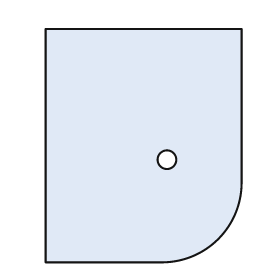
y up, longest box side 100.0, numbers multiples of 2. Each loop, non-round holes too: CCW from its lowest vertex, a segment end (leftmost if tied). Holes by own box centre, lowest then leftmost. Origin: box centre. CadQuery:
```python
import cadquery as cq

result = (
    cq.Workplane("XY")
    .moveTo(-42.0, -50.0)
    .lineTo(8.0, -50.0)
    .threePointArc((32.0, -40.0), (42.0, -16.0))
    .lineTo(42.0, 50.0)
    .lineTo(-42.0, 50.0)
    .close()
    .moveTo(10.0, -6.0)
    .circle(4.0)
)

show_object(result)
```